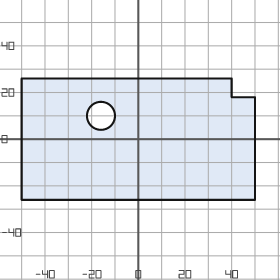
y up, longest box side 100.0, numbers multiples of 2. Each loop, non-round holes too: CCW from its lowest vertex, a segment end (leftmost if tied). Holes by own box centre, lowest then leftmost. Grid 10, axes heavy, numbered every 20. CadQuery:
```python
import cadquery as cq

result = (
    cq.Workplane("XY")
    .moveTo(-50.0, -26.0)
    .lineTo(50.0, -26.0)
    .lineTo(50.0, 18.0)
    .lineTo(40.0, 18.0)
    .lineTo(40.0, 26.0)
    .lineTo(-50.0, 26.0)
    .close()
    .moveTo(-16.0, 10.0)
    .circle(6.0)
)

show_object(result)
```